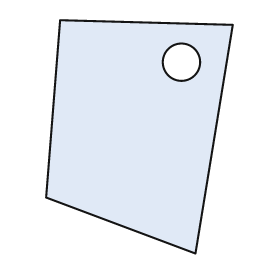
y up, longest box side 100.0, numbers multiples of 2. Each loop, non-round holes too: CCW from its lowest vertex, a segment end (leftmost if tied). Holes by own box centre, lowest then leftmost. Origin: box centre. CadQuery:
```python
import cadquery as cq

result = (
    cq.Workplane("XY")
    .moveTo(24.0, -50.0)
    .lineTo(40.0, 48.0)
    .lineTo(-34.0, 50.0)
    .lineTo(-40.0, -26.0)
    .close()
    .moveTo(18.0, 32.0)
    .circle(8.0)
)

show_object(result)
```